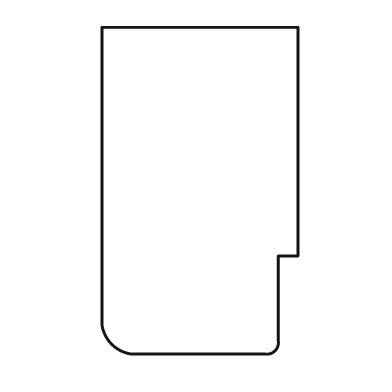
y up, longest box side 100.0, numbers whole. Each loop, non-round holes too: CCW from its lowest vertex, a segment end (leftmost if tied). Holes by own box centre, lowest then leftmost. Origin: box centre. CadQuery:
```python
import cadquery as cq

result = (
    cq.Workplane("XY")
    .moveTo(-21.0, -50.0)
    .lineTo(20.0, -50.0)
    .threePointArc((23.0, -49.0), (24.0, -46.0))
    .lineTo(24.0, -20.0)
    .lineTo(30.0, -20.0)
    .lineTo(30.0, 50.0)
    .lineTo(-30.0, 50.0)
    .lineTo(-30.0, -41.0)
    .threePointArc((-27.0, -47.0), (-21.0, -50.0))
    .close()
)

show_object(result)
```